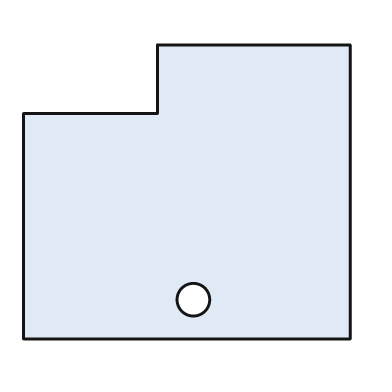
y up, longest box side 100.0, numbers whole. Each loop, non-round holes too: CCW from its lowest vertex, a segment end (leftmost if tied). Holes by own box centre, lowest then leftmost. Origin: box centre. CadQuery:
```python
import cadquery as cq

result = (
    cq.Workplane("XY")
    .moveTo(-50.0, -45.0)
    .lineTo(50.0, -45.0)
    .lineTo(50.0, 45.0)
    .lineTo(-9.0, 45.0)
    .lineTo(-9.0, 24.0)
    .lineTo(-50.0, 24.0)
    .close()
    .moveTo(2.0, -33.0)
    .circle(5.0)
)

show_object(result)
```